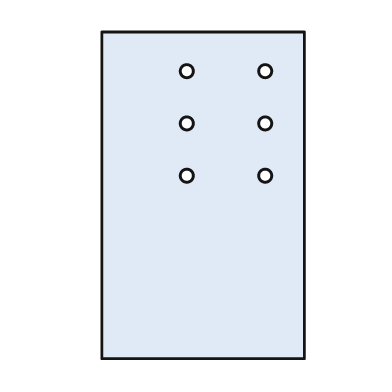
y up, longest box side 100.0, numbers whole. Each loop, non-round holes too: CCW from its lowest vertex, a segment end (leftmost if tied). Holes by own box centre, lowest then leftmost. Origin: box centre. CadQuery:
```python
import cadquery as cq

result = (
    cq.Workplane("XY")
    .moveTo(-31.0, -50.0)
    .lineTo(31.0, -50.0)
    .lineTo(31.0, 50.0)
    .lineTo(-31.0, 50.0)
    .close()
    .moveTo(-5.0, 6.0)
    .circle(2.0)
    .moveTo(19.0, 6.0)
    .circle(2.0)
    .moveTo(-5.0, 22.0)
    .circle(2.0)
    .moveTo(19.0, 22.0)
    .circle(2.0)
    .moveTo(-5.0, 38.0)
    .circle(2.0)
    .moveTo(19.0, 38.0)
    .circle(2.0)
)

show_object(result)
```